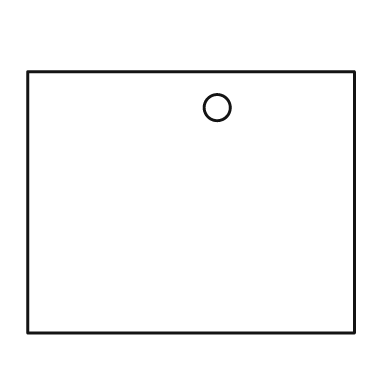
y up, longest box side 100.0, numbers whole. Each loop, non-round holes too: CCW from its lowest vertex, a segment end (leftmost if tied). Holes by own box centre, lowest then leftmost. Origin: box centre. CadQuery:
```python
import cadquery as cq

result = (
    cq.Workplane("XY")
    .moveTo(-50.0, -40.0)
    .lineTo(50.0, -40.0)
    .lineTo(50.0, 40.0)
    .lineTo(-50.0, 40.0)
    .close()
    .moveTo(8.0, 29.0)
    .circle(4.0)
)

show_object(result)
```